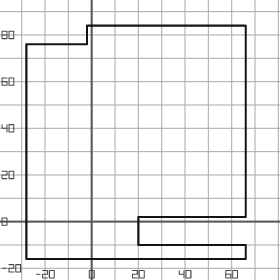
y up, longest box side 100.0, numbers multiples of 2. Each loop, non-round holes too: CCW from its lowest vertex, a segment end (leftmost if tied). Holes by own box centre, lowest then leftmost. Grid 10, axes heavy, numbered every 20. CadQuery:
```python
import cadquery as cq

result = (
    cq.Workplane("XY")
    .moveTo(-28.0, -16.0)
    .lineTo(66.0, -16.0)
    .lineTo(66.0, -10.0)
    .lineTo(20.0, -10.0)
    .lineTo(20.0, 2.0)
    .lineTo(66.0, 2.0)
    .lineTo(66.0, 84.0)
    .lineTo(-2.0, 84.0)
    .lineTo(-2.0, 76.0)
    .lineTo(-28.0, 76.0)
    .close()
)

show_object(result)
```